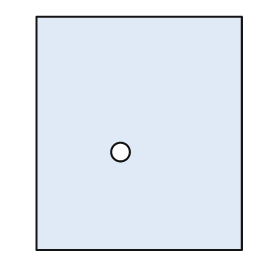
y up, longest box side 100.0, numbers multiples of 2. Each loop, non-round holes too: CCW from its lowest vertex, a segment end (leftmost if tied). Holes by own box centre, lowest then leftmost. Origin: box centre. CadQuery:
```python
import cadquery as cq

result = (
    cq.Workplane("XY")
    .moveTo(-44.0, -50.0)
    .lineTo(44.0, -50.0)
    .lineTo(44.0, 50.0)
    .lineTo(-44.0, 50.0)
    .close()
    .moveTo(-8.0, -8.0)
    .circle(4.0)
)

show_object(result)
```